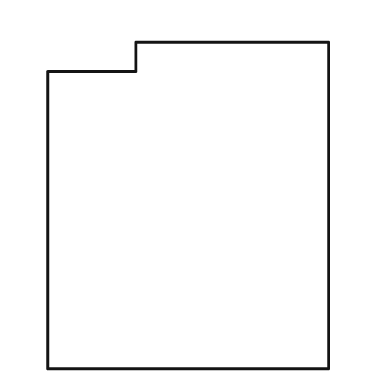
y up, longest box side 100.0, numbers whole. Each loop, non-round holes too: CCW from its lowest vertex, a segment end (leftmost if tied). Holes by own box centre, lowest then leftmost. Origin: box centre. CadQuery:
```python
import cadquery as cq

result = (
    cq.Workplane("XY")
    .moveTo(-43.0, -50.0)
    .lineTo(43.0, -50.0)
    .lineTo(43.0, 50.0)
    .lineTo(-16.0, 50.0)
    .lineTo(-16.0, 41.0)
    .lineTo(-43.0, 41.0)
    .close()
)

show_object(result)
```